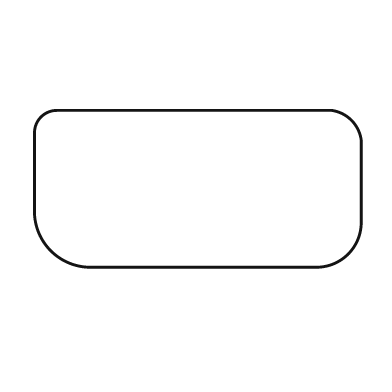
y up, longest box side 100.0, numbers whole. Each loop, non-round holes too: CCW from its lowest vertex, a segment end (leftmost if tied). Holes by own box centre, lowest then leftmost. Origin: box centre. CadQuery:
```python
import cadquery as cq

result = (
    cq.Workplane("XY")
    .moveTo(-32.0, -24.0)
    .lineTo(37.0, -24.0)
    .threePointArc((46.0, -20.0), (50.0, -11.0))
    .lineTo(50.0, 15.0)
    .threePointArc((47.0, 21.0), (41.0, 24.0))
    .lineTo(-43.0, 24.0)
    .threePointArc((-48.0, 22.0), (-50.0, 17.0))
    .lineTo(-50.0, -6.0)
    .threePointArc((-45.0, -19.0), (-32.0, -24.0))
    .close()
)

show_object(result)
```